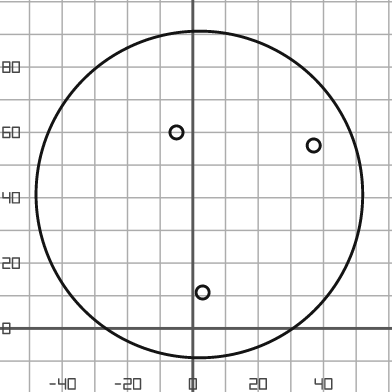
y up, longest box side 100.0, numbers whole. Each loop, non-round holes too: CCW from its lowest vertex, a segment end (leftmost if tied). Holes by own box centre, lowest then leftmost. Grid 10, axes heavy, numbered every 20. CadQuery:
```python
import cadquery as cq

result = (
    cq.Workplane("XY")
    .moveTo(2.0, 41.0)
    .circle(50.0)
    .moveTo(3.0, 11.0)
    .circle(2.0)
    .moveTo(37.0, 56.0)
    .circle(2.0)
    .moveTo(-5.0, 60.0)
    .circle(2.0)
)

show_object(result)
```